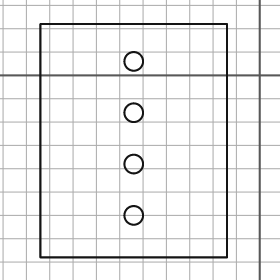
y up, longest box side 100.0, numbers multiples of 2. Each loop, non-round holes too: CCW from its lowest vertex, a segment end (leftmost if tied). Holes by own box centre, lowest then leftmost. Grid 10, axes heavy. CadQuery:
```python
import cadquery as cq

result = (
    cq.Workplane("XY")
    .moveTo(-94.0, -78.0)
    .lineTo(-14.0, -78.0)
    .lineTo(-14.0, 22.0)
    .lineTo(-94.0, 22.0)
    .close()
    .moveTo(-54.0, -60.0)
    .circle(4.0)
    .moveTo(-54.0, -38.0)
    .circle(4.0)
    .moveTo(-54.0, -16.0)
    .circle(4.0)
    .moveTo(-54.0, 6.0)
    .circle(4.0)
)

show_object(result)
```